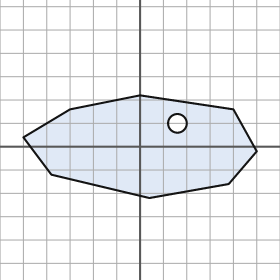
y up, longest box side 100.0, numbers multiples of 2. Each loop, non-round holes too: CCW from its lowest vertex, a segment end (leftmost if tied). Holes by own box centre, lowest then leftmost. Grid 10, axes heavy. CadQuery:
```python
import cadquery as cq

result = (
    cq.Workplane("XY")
    .moveTo(4.0, -22.0)
    .lineTo(38.0, -16.0)
    .lineTo(50.0, -2.0)
    .lineTo(40.0, 16.0)
    .lineTo(0.0, 22.0)
    .lineTo(-30.0, 16.0)
    .lineTo(-50.0, 4.0)
    .lineTo(-38.0, -12.0)
    .close()
    .moveTo(16.0, 10.0)
    .circle(4.0)
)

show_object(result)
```